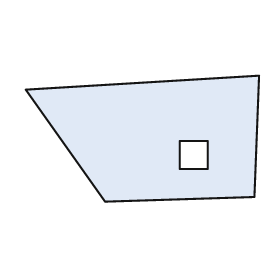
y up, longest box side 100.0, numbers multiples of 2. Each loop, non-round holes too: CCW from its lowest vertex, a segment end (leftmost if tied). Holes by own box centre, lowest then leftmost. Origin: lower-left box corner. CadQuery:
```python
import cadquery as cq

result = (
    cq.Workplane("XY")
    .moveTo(34.0, 0.0)
    .lineTo(98.0, 2.0)
    .lineTo(100.0, 54.0)
    .lineTo(0.0, 48.0)
    .close()
    .moveTo(66.0, 14.0)
    .lineTo(78.0, 14.0)
    .lineTo(78.0, 26.0)
    .lineTo(66.0, 26.0)
    .close()
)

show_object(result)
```